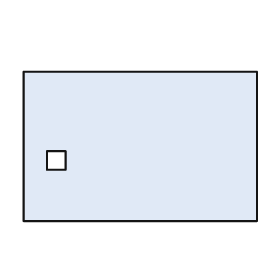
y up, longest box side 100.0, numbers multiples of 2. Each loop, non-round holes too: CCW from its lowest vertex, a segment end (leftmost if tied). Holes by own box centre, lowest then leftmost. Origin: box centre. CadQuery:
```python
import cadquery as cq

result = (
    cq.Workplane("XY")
    .moveTo(-50.0, -32.0)
    .lineTo(50.0, -32.0)
    .lineTo(50.0, 32.0)
    .lineTo(-50.0, 32.0)
    .close()
    .moveTo(-40.0, -10.0)
    .lineTo(-32.0, -10.0)
    .lineTo(-32.0, -2.0)
    .lineTo(-40.0, -2.0)
    .close()
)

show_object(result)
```